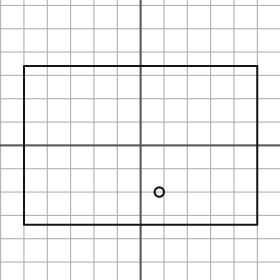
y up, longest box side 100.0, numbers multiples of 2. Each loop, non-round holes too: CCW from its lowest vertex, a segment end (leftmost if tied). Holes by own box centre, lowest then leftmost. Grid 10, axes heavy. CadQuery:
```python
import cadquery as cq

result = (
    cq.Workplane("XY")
    .moveTo(-50.0, -34.0)
    .lineTo(50.0, -34.0)
    .lineTo(50.0, 34.0)
    .lineTo(-50.0, 34.0)
    .close()
    .moveTo(8.0, -20.0)
    .circle(2.0)
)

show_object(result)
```